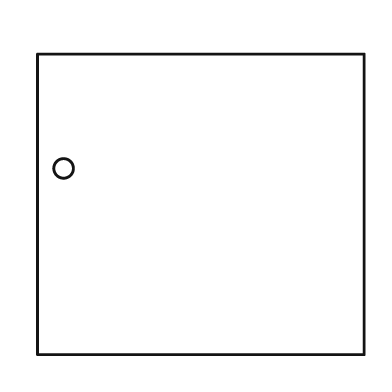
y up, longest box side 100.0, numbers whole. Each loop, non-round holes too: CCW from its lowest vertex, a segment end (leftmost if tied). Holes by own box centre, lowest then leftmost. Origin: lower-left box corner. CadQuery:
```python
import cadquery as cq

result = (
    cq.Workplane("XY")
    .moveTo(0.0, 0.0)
    .lineTo(100.0, 0.0)
    .lineTo(100.0, 92.0)
    .lineTo(0.0, 92.0)
    .close()
    .moveTo(8.0, 57.0)
    .circle(3.0)
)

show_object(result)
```